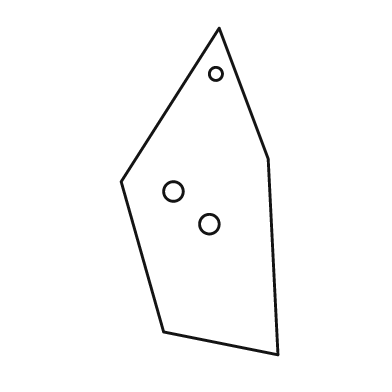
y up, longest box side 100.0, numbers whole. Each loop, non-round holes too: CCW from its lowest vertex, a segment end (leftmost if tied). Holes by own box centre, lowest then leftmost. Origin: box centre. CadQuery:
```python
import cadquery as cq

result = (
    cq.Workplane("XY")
    .moveTo(24.0, -50.0)
    .lineTo(21.0, 10.0)
    .lineTo(6.0, 50.0)
    .lineTo(-24.0, 3.0)
    .lineTo(-11.0, -43.0)
    .close()
    .moveTo(3.0, -10.0)
    .circle(3.0)
    .moveTo(-8.0, 0.0)
    .circle(3.0)
    .moveTo(5.0, 36.0)
    .circle(2.0)
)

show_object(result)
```